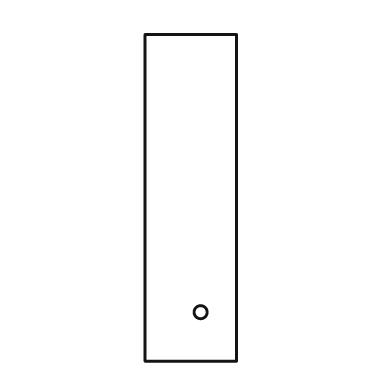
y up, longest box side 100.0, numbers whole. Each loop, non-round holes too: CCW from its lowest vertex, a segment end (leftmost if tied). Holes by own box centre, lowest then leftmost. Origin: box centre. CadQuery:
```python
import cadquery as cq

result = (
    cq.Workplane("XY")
    .moveTo(-14.0, -50.0)
    .lineTo(14.0, -50.0)
    .lineTo(14.0, 50.0)
    .lineTo(-14.0, 50.0)
    .close()
    .moveTo(3.0, -35.0)
    .circle(2.0)
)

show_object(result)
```